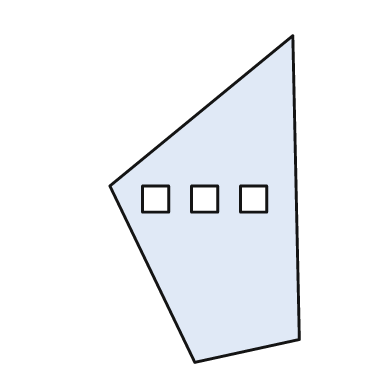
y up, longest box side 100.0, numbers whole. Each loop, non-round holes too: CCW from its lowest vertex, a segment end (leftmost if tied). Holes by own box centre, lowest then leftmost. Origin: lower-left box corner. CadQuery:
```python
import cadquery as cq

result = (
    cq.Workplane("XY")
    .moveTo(26.0, 0.0)
    .lineTo(58.0, 7.0)
    .lineTo(56.0, 100.0)
    .lineTo(0.0, 54.0)
    .close()
    .moveTo(10.0, 46.0)
    .lineTo(18.0, 46.0)
    .lineTo(18.0, 54.0)
    .lineTo(10.0, 54.0)
    .close()
    .moveTo(25.0, 46.0)
    .lineTo(33.0, 46.0)
    .lineTo(33.0, 54.0)
    .lineTo(25.0, 54.0)
    .close()
    .moveTo(40.0, 46.0)
    .lineTo(48.0, 46.0)
    .lineTo(48.0, 54.0)
    .lineTo(40.0, 54.0)
    .close()
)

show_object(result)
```